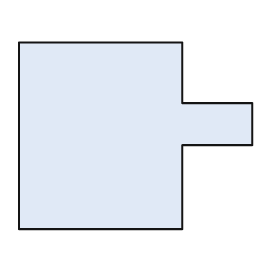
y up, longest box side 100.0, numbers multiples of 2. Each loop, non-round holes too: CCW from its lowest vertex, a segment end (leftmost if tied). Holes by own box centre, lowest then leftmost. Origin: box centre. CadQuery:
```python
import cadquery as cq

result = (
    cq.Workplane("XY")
    .moveTo(-50.0, -40.0)
    .lineTo(20.0, -40.0)
    .lineTo(20.0, -4.0)
    .lineTo(50.0, -4.0)
    .lineTo(50.0, 14.0)
    .lineTo(20.0, 14.0)
    .lineTo(20.0, 40.0)
    .lineTo(-50.0, 40.0)
    .close()
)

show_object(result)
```